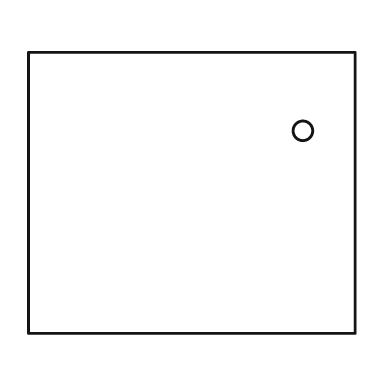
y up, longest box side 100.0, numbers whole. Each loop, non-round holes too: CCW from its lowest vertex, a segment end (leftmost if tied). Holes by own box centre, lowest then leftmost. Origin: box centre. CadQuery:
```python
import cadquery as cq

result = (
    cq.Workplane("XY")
    .moveTo(-50.0, -43.0)
    .lineTo(50.0, -43.0)
    .lineTo(50.0, 43.0)
    .lineTo(-50.0, 43.0)
    .close()
    .moveTo(34.0, 19.0)
    .circle(3.0)
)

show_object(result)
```